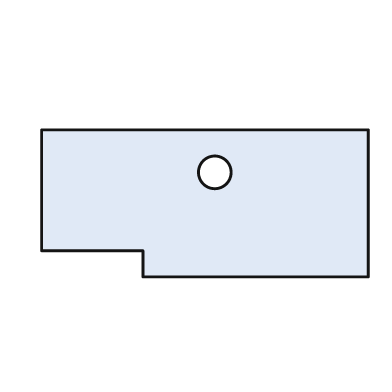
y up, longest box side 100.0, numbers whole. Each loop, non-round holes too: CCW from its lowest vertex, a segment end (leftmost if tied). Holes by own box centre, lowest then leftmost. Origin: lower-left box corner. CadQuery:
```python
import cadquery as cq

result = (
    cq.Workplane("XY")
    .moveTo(31.0, 0.0)
    .lineTo(100.0, 0.0)
    .lineTo(100.0, 45.0)
    .lineTo(0.0, 45.0)
    .lineTo(0.0, 8.0)
    .lineTo(31.0, 8.0)
    .close()
    .moveTo(53.0, 32.0)
    .circle(5.0)
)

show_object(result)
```